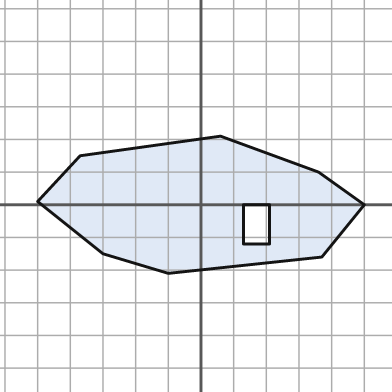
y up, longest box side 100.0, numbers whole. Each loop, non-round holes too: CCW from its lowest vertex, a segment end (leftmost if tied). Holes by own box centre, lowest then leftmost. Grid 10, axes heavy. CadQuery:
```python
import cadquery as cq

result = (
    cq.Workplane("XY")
    .moveTo(-10.0, -21.0)
    .lineTo(37.0, -16.0)
    .lineTo(50.0, 0.0)
    .lineTo(36.0, 10.0)
    .lineTo(6.0, 21.0)
    .lineTo(-37.0, 15.0)
    .lineTo(-50.0, 1.0)
    .lineTo(-30.0, -15.0)
    .close()
    .moveTo(13.0, -12.0)
    .lineTo(21.0, -12.0)
    .lineTo(21.0, 0.0)
    .lineTo(13.0, 0.0)
    .close()
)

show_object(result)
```